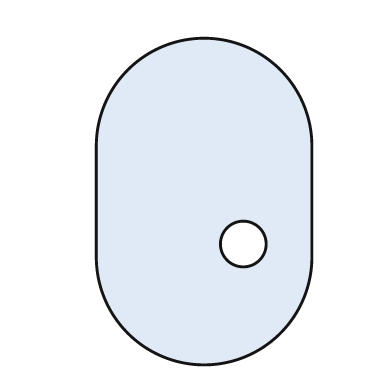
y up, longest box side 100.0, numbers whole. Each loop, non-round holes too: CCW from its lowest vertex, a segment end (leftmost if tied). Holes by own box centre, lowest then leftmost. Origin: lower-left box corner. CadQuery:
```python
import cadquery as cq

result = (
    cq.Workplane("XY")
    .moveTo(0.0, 33.0)
    .threePointArc((33.0, 0.0), (66.0, 33.0))
    .lineTo(66.0, 67.0)
    .threePointArc((33.0, 100.0), (0.0, 67.0))
    .close()
    .moveTo(45.0, 37.0)
    .circle(7.0)
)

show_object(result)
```